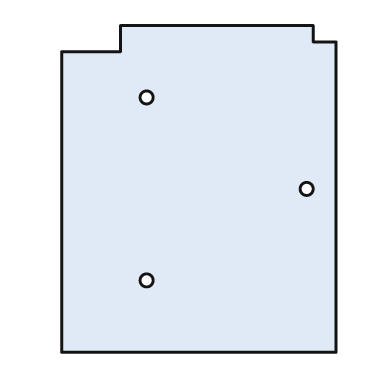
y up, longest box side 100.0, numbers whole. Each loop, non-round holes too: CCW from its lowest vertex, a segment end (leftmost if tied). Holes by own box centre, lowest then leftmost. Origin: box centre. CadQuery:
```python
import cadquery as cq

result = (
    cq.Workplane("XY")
    .moveTo(-42.0, -50.0)
    .lineTo(42.0, -50.0)
    .lineTo(42.0, 45.0)
    .lineTo(35.0, 45.0)
    .lineTo(35.0, 50.0)
    .lineTo(-24.0, 50.0)
    .lineTo(-24.0, 42.0)
    .lineTo(-42.0, 42.0)
    .close()
    .moveTo(-16.0, -28.0)
    .circle(2.0)
    .moveTo(33.0, 0.0)
    .circle(2.0)
    .moveTo(-16.0, 28.0)
    .circle(2.0)
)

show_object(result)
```